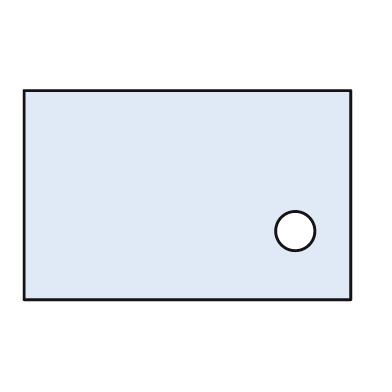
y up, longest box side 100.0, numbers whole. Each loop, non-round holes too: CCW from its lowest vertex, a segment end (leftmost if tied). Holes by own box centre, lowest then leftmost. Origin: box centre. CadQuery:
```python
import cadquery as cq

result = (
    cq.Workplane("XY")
    .moveTo(-50.0, -32.0)
    .lineTo(50.0, -32.0)
    .lineTo(50.0, 32.0)
    .lineTo(-50.0, 32.0)
    .close()
    .moveTo(33.0, -11.0)
    .circle(6.0)
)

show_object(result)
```